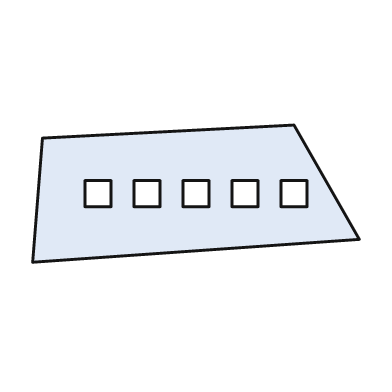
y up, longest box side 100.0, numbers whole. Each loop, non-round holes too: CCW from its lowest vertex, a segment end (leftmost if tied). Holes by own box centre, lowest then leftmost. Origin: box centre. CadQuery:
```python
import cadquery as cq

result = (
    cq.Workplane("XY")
    .moveTo(-50.0, -21.0)
    .lineTo(50.0, -14.0)
    .lineTo(30.0, 21.0)
    .lineTo(-47.0, 17.0)
    .close()
    .moveTo(-34.0, -4.0)
    .lineTo(-26.0, -4.0)
    .lineTo(-26.0, 4.0)
    .lineTo(-34.0, 4.0)
    .close()
    .moveTo(-19.0, -4.0)
    .lineTo(-11.0, -4.0)
    .lineTo(-11.0, 4.0)
    .lineTo(-19.0, 4.0)
    .close()
    .moveTo(-4.0, -4.0)
    .lineTo(4.0, -4.0)
    .lineTo(4.0, 4.0)
    .lineTo(-4.0, 4.0)
    .close()
    .moveTo(11.0, -4.0)
    .lineTo(19.0, -4.0)
    .lineTo(19.0, 4.0)
    .lineTo(11.0, 4.0)
    .close()
    .moveTo(26.0, -4.0)
    .lineTo(34.0, -4.0)
    .lineTo(34.0, 4.0)
    .lineTo(26.0, 4.0)
    .close()
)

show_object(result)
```